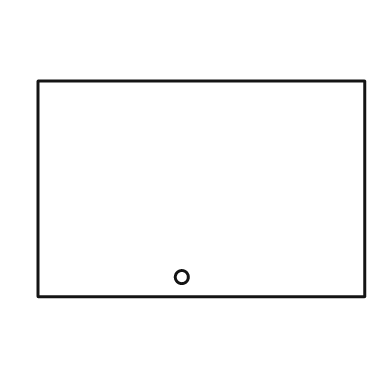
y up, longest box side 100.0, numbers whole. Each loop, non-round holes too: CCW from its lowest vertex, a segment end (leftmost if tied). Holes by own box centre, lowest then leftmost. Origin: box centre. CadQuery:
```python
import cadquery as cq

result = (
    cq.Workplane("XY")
    .moveTo(-50.0, -33.0)
    .lineTo(50.0, -33.0)
    .lineTo(50.0, 33.0)
    .lineTo(-50.0, 33.0)
    .close()
    .moveTo(-6.0, -27.0)
    .circle(2.0)
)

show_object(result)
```